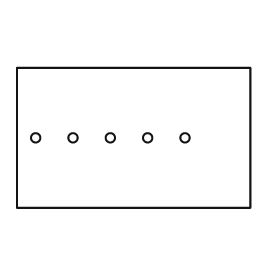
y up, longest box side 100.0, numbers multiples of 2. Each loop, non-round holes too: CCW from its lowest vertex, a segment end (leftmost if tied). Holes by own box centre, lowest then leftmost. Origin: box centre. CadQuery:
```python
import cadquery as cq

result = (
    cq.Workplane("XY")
    .moveTo(-50.0, -30.0)
    .lineTo(50.0, -30.0)
    .lineTo(50.0, 30.0)
    .lineTo(-50.0, 30.0)
    .close()
    .moveTo(-42.0, 0.0)
    .circle(2.0)
    .moveTo(-26.0, 0.0)
    .circle(2.0)
    .moveTo(-10.0, 0.0)
    .circle(2.0)
    .moveTo(6.0, 0.0)
    .circle(2.0)
    .moveTo(22.0, 0.0)
    .circle(2.0)
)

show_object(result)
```